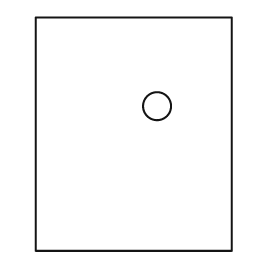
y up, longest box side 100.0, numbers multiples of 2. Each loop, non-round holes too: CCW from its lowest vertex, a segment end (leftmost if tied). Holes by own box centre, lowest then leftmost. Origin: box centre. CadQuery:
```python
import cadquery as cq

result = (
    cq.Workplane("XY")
    .moveTo(-42.0, -50.0)
    .lineTo(42.0, -50.0)
    .lineTo(42.0, 50.0)
    .lineTo(-42.0, 50.0)
    .close()
    .moveTo(10.0, 12.0)
    .circle(6.0)
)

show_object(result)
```